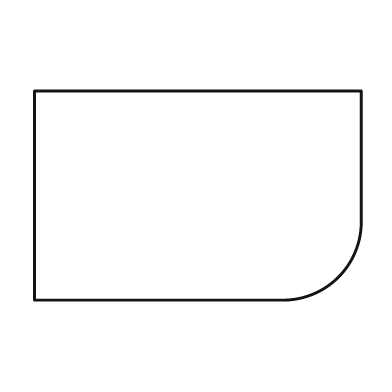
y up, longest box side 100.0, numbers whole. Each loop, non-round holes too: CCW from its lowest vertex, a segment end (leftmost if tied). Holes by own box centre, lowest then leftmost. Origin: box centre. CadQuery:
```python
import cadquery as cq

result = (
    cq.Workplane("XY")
    .moveTo(-50.0, -32.0)
    .lineTo(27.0, -32.0)
    .threePointArc((43.0, -25.0), (50.0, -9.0))
    .lineTo(50.0, 32.0)
    .lineTo(-50.0, 32.0)
    .close()
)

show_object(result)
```